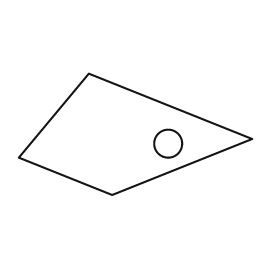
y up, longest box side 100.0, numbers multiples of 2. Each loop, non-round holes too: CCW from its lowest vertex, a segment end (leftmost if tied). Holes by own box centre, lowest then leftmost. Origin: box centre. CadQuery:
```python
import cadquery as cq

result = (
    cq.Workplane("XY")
    .moveTo(-10.0, -26.0)
    .lineTo(50.0, -2.0)
    .lineTo(-20.0, 26.0)
    .lineTo(-50.0, -10.0)
    .close()
    .moveTo(14.0, -4.0)
    .circle(6.0)
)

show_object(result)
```